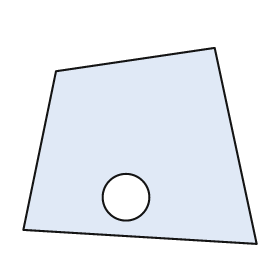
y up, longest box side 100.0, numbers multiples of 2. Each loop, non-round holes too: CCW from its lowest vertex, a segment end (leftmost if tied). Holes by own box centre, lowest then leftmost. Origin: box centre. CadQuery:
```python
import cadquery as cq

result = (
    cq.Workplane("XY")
    .moveTo(50.0, -42.0)
    .lineTo(32.0, 42.0)
    .lineTo(-36.0, 32.0)
    .lineTo(-50.0, -36.0)
    .close()
    .moveTo(-6.0, -22.0)
    .circle(10.0)
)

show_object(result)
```